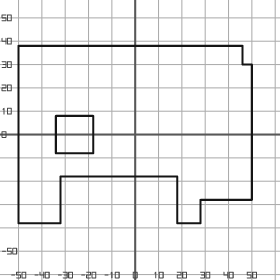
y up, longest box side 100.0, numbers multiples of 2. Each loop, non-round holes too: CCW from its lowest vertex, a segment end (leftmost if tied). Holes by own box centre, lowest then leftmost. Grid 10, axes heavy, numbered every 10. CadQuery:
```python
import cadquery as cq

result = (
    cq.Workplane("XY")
    .moveTo(-50.0, -38.0)
    .lineTo(-32.0, -38.0)
    .lineTo(-32.0, -18.0)
    .lineTo(18.0, -18.0)
    .lineTo(18.0, -38.0)
    .lineTo(28.0, -38.0)
    .lineTo(28.0, -28.0)
    .lineTo(50.0, -28.0)
    .lineTo(50.0, 30.0)
    .lineTo(46.0, 30.0)
    .lineTo(46.0, 38.0)
    .lineTo(-50.0, 38.0)
    .close()
    .moveTo(-34.0, -8.0)
    .lineTo(-18.0, -8.0)
    .lineTo(-18.0, 8.0)
    .lineTo(-34.0, 8.0)
    .close()
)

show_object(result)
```